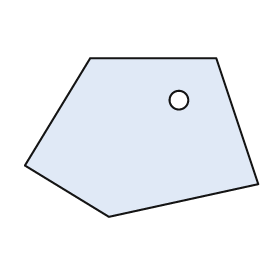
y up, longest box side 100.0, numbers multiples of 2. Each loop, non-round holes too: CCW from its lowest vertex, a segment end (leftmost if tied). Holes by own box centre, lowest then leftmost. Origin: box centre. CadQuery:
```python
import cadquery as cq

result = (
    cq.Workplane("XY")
    .moveTo(-14.0, -34.0)
    .lineTo(50.0, -20.0)
    .lineTo(32.0, 34.0)
    .lineTo(-22.0, 34.0)
    .lineTo(-50.0, -12.0)
    .close()
    .moveTo(16.0, 16.0)
    .circle(4.0)
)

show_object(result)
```